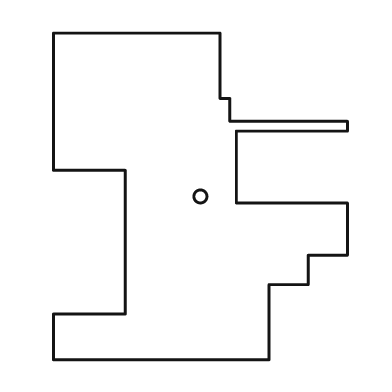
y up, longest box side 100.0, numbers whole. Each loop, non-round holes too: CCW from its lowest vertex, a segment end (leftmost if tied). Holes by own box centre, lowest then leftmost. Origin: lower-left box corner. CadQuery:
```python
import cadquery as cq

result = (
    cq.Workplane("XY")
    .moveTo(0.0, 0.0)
    .lineTo(66.0, 0.0)
    .lineTo(66.0, 23.0)
    .lineTo(78.0, 23.0)
    .lineTo(78.0, 32.0)
    .lineTo(90.0, 32.0)
    .lineTo(90.0, 48.0)
    .lineTo(56.0, 48.0)
    .lineTo(56.0, 70.0)
    .lineTo(90.0, 70.0)
    .lineTo(90.0, 73.0)
    .lineTo(54.0, 73.0)
    .lineTo(54.0, 80.0)
    .lineTo(51.0, 80.0)
    .lineTo(51.0, 100.0)
    .lineTo(0.0, 100.0)
    .lineTo(0.0, 58.0)
    .lineTo(22.0, 58.0)
    .lineTo(22.0, 14.0)
    .lineTo(0.0, 14.0)
    .close()
    .moveTo(45.0, 50.0)
    .circle(2.0)
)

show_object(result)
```